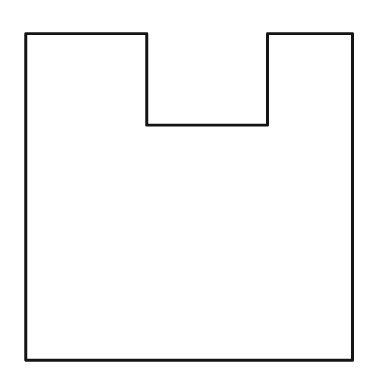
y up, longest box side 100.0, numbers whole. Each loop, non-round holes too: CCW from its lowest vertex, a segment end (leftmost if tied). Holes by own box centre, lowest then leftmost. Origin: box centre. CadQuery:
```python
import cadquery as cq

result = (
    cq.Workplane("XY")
    .moveTo(-50.0, -50.0)
    .lineTo(50.0, -50.0)
    .lineTo(50.0, 50.0)
    .lineTo(24.0, 50.0)
    .lineTo(24.0, 22.0)
    .lineTo(-13.0, 22.0)
    .lineTo(-13.0, 50.0)
    .lineTo(-50.0, 50.0)
    .close()
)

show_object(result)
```